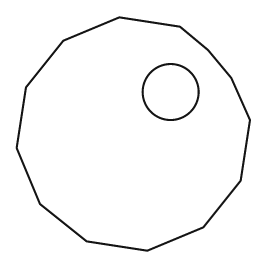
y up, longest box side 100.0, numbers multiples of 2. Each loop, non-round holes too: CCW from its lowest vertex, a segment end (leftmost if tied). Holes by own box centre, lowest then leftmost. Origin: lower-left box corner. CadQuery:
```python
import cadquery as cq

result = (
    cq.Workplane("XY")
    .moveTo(56.0, 0.0)
    .lineTo(80.0, 10.0)
    .lineTo(96.0, 30.0)
    .lineTo(100.0, 56.0)
    .lineTo(92.0, 74.0)
    .lineTo(82.0, 86.0)
    .lineTo(70.0, 96.0)
    .lineTo(44.0, 100.0)
    .lineTo(20.0, 90.0)
    .lineTo(4.0, 70.0)
    .lineTo(0.0, 44.0)
    .lineTo(10.0, 20.0)
    .lineTo(30.0, 4.0)
    .close()
    .moveTo(66.0, 68.0)
    .circle(12.0)
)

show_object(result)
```